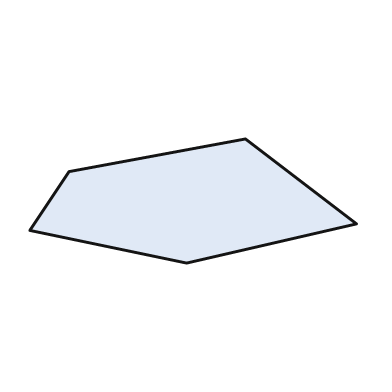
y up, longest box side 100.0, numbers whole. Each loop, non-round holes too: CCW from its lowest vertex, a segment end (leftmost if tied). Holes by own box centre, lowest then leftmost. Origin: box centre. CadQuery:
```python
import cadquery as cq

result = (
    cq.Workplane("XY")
    .moveTo(-2.0, -19.0)
    .lineTo(50.0, -7.0)
    .lineTo(16.0, 19.0)
    .lineTo(-38.0, 9.0)
    .lineTo(-50.0, -9.0)
    .close()
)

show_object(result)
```